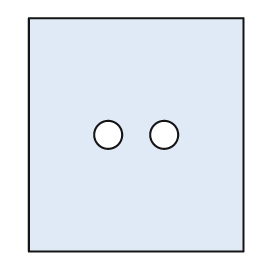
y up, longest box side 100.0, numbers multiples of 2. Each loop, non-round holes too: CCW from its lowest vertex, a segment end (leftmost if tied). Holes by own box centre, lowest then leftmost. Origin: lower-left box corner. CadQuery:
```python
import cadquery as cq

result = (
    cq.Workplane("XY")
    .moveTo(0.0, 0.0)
    .lineTo(92.0, 0.0)
    .lineTo(92.0, 100.0)
    .lineTo(0.0, 100.0)
    .close()
    .moveTo(34.0, 50.0)
    .circle(6.0)
    .moveTo(58.0, 50.0)
    .circle(6.0)
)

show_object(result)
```